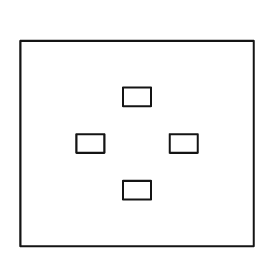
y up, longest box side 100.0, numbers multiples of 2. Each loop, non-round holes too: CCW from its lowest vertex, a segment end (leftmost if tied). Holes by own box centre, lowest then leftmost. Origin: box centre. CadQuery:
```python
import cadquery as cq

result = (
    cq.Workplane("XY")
    .moveTo(-50.0, -44.0)
    .lineTo(50.0, -44.0)
    .lineTo(50.0, 44.0)
    .lineTo(-50.0, 44.0)
    .close()
    .moveTo(-6.0, -24.0)
    .lineTo(6.0, -24.0)
    .lineTo(6.0, -16.0)
    .lineTo(-6.0, -16.0)
    .close()
    .moveTo(-26.0, -4.0)
    .lineTo(-14.0, -4.0)
    .lineTo(-14.0, 4.0)
    .lineTo(-26.0, 4.0)
    .close()
    .moveTo(14.0, -4.0)
    .lineTo(26.0, -4.0)
    .lineTo(26.0, 4.0)
    .lineTo(14.0, 4.0)
    .close()
    .moveTo(-6.0, 16.0)
    .lineTo(6.0, 16.0)
    .lineTo(6.0, 24.0)
    .lineTo(-6.0, 24.0)
    .close()
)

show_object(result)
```